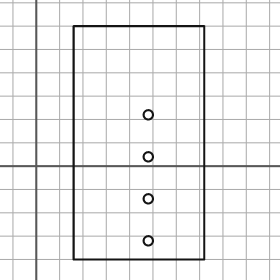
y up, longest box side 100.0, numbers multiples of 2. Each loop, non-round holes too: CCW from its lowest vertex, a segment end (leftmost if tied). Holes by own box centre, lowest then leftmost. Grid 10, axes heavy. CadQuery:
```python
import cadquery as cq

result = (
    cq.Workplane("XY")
    .moveTo(16.0, -40.0)
    .lineTo(72.0, -40.0)
    .lineTo(72.0, 60.0)
    .lineTo(16.0, 60.0)
    .close()
    .moveTo(48.0, -32.0)
    .circle(2.0)
    .moveTo(48.0, -14.0)
    .circle(2.0)
    .moveTo(48.0, 4.0)
    .circle(2.0)
    .moveTo(48.0, 22.0)
    .circle(2.0)
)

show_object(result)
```